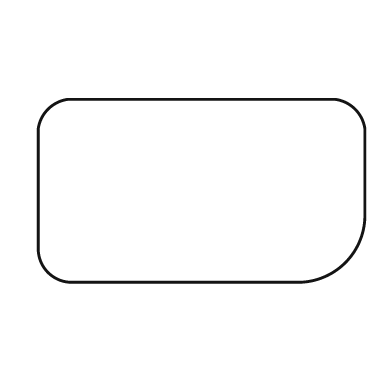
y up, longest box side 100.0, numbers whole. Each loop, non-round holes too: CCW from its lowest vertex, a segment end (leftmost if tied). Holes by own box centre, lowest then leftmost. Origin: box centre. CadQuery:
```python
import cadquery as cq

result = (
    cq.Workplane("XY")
    .moveTo(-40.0, -28.0)
    .lineTo(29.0, -28.0)
    .threePointArc((44.0, -22.0), (50.0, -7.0))
    .lineTo(50.0, 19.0)
    .threePointArc((47.0, 25.0), (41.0, 28.0))
    .lineTo(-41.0, 28.0)
    .threePointArc((-47.0, 25.0), (-50.0, 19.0))
    .lineTo(-50.0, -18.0)
    .threePointArc((-47.0, -25.0), (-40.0, -28.0))
    .close()
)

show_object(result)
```